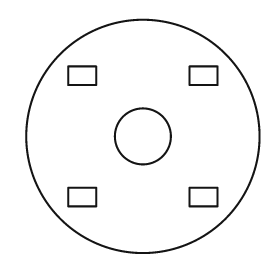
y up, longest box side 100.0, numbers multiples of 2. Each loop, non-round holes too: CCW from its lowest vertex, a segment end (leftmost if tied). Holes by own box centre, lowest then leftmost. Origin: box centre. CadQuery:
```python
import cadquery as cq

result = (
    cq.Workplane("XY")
    .moveTo(0.0, 0.0)
    .circle(50.0)
    .moveTo(-32.0, -30.0)
    .lineTo(-20.0, -30.0)
    .lineTo(-20.0, -22.0)
    .lineTo(-32.0, -22.0)
    .close()
    .moveTo(20.0, -30.0)
    .lineTo(32.0, -30.0)
    .lineTo(32.0, -22.0)
    .lineTo(20.0, -22.0)
    .close()
    .moveTo(0.0, 0.0)
    .circle(12.0)
    .moveTo(-32.0, 22.0)
    .lineTo(-20.0, 22.0)
    .lineTo(-20.0, 30.0)
    .lineTo(-32.0, 30.0)
    .close()
    .moveTo(20.0, 22.0)
    .lineTo(32.0, 22.0)
    .lineTo(32.0, 30.0)
    .lineTo(20.0, 30.0)
    .close()
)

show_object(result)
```